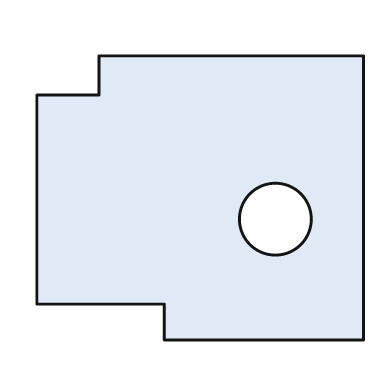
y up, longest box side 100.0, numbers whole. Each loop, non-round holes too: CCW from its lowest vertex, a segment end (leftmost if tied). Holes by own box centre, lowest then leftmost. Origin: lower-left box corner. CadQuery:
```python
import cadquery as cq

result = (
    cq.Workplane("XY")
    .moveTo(39.0, 0.0)
    .lineTo(100.0, 0.0)
    .lineTo(100.0, 87.0)
    .lineTo(19.0, 87.0)
    .lineTo(19.0, 75.0)
    .lineTo(0.0, 75.0)
    .lineTo(0.0, 11.0)
    .lineTo(39.0, 11.0)
    .close()
    .moveTo(73.0, 37.0)
    .circle(11.0)
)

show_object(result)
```